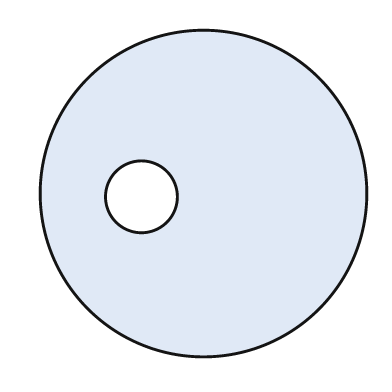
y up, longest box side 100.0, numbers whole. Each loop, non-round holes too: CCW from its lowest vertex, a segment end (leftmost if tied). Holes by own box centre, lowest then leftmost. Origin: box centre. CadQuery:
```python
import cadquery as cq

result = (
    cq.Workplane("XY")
    .moveTo(0.0, 0.0)
    .circle(50.0)
    .moveTo(-19.0, -1.0)
    .circle(11.0)
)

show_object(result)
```